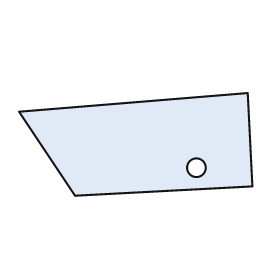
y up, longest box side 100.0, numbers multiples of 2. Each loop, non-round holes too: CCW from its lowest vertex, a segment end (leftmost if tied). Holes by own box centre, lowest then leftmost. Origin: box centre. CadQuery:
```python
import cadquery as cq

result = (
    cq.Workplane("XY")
    .moveTo(-26.0, -22.0)
    .lineTo(50.0, -18.0)
    .lineTo(48.0, 22.0)
    .lineTo(-50.0, 14.0)
    .close()
    .moveTo(26.0, -10.0)
    .circle(4.0)
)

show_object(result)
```